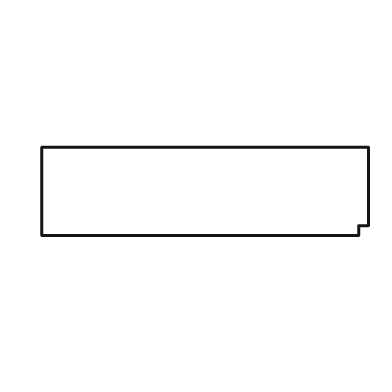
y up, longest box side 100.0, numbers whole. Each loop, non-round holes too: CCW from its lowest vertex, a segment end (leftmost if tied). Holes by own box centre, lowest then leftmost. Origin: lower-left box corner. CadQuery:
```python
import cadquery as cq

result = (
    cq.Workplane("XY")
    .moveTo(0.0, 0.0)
    .lineTo(97.0, 0.0)
    .lineTo(97.0, 3.0)
    .lineTo(100.0, 3.0)
    .lineTo(100.0, 27.0)
    .lineTo(0.0, 27.0)
    .close()
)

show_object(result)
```